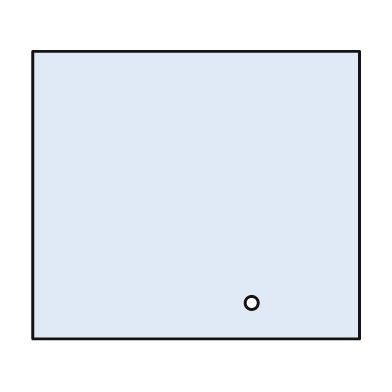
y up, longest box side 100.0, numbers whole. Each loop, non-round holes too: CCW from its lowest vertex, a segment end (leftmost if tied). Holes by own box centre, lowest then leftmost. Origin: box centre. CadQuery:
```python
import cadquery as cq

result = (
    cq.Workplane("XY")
    .moveTo(-50.0, -44.0)
    .lineTo(50.0, -44.0)
    .lineTo(50.0, 44.0)
    .lineTo(-50.0, 44.0)
    .close()
    .moveTo(17.0, -33.0)
    .circle(2.0)
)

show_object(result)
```